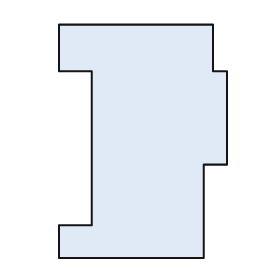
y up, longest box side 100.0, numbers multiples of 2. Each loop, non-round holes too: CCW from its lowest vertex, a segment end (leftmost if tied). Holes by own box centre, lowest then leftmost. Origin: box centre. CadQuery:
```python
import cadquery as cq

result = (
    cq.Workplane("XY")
    .moveTo(-36.0, -50.0)
    .lineTo(26.0, -50.0)
    .lineTo(26.0, -10.0)
    .lineTo(36.0, -10.0)
    .lineTo(36.0, 30.0)
    .lineTo(30.0, 30.0)
    .lineTo(30.0, 50.0)
    .lineTo(-36.0, 50.0)
    .lineTo(-36.0, 30.0)
    .lineTo(-22.0, 30.0)
    .lineTo(-22.0, -36.0)
    .lineTo(-36.0, -36.0)
    .close()
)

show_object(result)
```